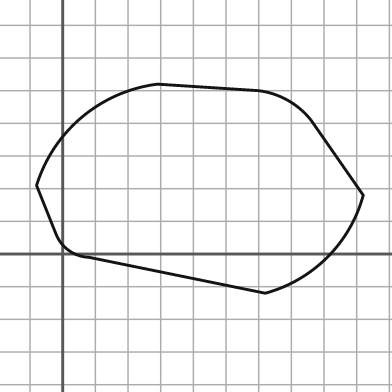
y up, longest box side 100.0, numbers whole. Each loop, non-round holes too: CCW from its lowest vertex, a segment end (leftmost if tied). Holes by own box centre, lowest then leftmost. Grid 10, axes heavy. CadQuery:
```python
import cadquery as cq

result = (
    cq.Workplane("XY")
    .moveTo(62.0, -12.0)
    .threePointArc((81.0, -1.0), (92.0, 18.0))
    .lineTo(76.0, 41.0)
    .threePointArc((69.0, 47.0), (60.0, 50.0))
    .lineTo(29.0, 52.0)
    .threePointArc((6.0, 42.0), (-8.0, 21.0))
    .lineTo(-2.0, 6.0)
    .threePointArc((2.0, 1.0), (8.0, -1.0))
    .close()
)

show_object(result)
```